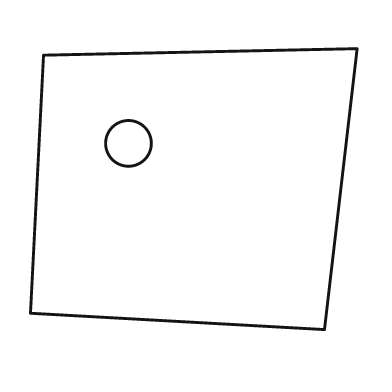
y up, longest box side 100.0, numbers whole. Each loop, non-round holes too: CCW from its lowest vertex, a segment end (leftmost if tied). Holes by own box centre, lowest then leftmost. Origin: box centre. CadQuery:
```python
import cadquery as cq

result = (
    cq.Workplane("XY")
    .moveTo(40.0, -43.0)
    .lineTo(50.0, 43.0)
    .lineTo(-46.0, 41.0)
    .lineTo(-50.0, -38.0)
    .close()
    .moveTo(-20.0, 14.0)
    .circle(7.0)
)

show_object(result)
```